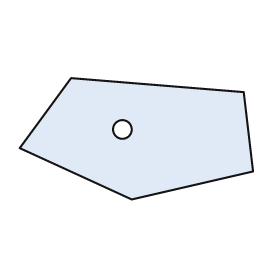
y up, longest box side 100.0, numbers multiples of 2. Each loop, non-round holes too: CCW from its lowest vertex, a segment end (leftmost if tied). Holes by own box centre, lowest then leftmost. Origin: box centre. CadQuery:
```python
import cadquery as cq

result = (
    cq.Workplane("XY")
    .moveTo(-2.0, -26.0)
    .lineTo(50.0, -14.0)
    .lineTo(46.0, 20.0)
    .lineTo(-28.0, 26.0)
    .lineTo(-50.0, -4.0)
    .close()
    .moveTo(-6.0, 4.0)
    .circle(4.0)
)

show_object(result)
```